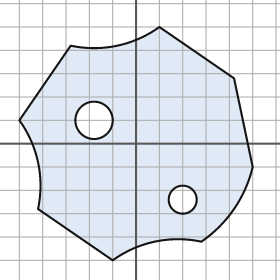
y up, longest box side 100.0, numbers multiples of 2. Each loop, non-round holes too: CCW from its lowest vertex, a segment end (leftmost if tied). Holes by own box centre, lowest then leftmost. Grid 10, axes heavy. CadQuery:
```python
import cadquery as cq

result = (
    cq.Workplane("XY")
    .moveTo(-10.0, -50.0)
    .threePointArc((8.0, -42.0), (28.0, -42.0))
    .threePointArc((42.0, -28.0), (50.0, -10.0))
    .lineTo(42.0, 28.0)
    .lineTo(10.0, 50.0)
    .threePointArc((-8.0, 42.0), (-28.0, 42.0))
    .lineTo(-50.0, 10.0)
    .threePointArc((-42.0, -8.0), (-42.0, -28.0))
    .close()
    .moveTo(20.0, -24.0)
    .circle(6.0)
    .moveTo(-18.0, 10.0)
    .circle(8.0)
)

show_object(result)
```